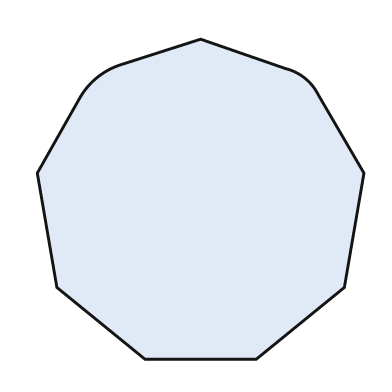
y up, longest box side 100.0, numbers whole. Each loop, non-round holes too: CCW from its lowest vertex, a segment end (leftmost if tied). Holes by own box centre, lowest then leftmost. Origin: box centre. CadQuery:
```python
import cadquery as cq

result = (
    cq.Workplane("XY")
    .moveTo(-17.0, -49.0)
    .lineTo(17.0, -49.0)
    .lineTo(44.0, -27.0)
    .lineTo(50.0, 8.0)
    .lineTo(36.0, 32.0)
    .threePointArc((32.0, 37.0), (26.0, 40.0))
    .lineTo(0.0, 49.0)
    .lineTo(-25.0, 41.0)
    .threePointArc((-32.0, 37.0), (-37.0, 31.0))
    .lineTo(-50.0, 8.0)
    .lineTo(-44.0, -27.0)
    .close()
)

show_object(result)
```